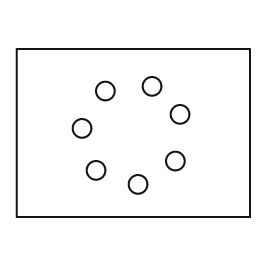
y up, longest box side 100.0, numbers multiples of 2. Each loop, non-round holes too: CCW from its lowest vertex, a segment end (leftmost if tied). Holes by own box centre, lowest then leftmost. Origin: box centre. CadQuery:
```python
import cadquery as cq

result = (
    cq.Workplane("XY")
    .moveTo(-50.0, -36.0)
    .lineTo(50.0, -36.0)
    .lineTo(50.0, 36.0)
    .lineTo(-50.0, 36.0)
    .close()
    .moveTo(2.0, -22.0)
    .circle(4.0)
    .moveTo(-16.0, -16.0)
    .circle(4.0)
    .moveTo(18.0, -12.0)
    .circle(4.0)
    .moveTo(-22.0, 2.0)
    .circle(4.0)
    .moveTo(20.0, 8.0)
    .circle(4.0)
    .moveTo(-12.0, 18.0)
    .circle(4.0)
    .moveTo(8.0, 20.0)
    .circle(4.0)
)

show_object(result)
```